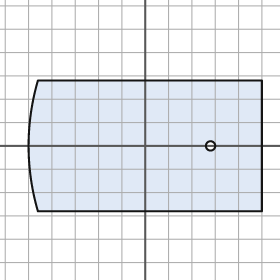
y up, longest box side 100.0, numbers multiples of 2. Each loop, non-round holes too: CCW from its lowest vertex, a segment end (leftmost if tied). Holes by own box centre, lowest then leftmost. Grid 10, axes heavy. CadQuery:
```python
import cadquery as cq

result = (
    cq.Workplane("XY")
    .moveTo(-46.0, -28.0)
    .lineTo(50.0, -28.0)
    .lineTo(50.0, 28.0)
    .lineTo(-46.0, 28.0)
    .threePointArc((-50.0, 0.0), (-46.0, -28.0))
    .close()
    .moveTo(28.0, 0.0)
    .circle(2.0)
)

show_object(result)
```